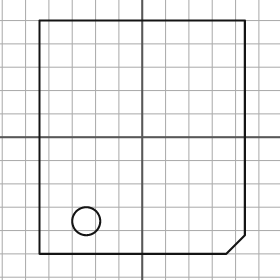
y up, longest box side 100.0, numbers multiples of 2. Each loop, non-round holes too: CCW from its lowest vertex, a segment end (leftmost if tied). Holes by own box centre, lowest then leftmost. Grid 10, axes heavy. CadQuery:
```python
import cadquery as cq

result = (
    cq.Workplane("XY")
    .moveTo(-44.0, -50.0)
    .lineTo(36.0, -50.0)
    .lineTo(44.0, -42.0)
    .lineTo(44.0, 50.0)
    .lineTo(-44.0, 50.0)
    .close()
    .moveTo(-24.0, -36.0)
    .circle(6.0)
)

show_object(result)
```